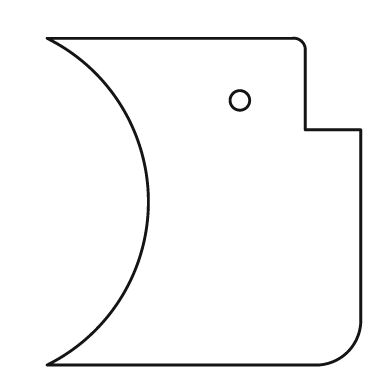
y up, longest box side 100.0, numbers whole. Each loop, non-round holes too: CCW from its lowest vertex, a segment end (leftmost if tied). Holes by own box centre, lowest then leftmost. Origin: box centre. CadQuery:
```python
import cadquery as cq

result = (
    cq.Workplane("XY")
    .moveTo(-48.0, -50.0)
    .lineTo(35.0, -50.0)
    .threePointArc((44.0, -46.0), (48.0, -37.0))
    .lineTo(48.0, 22.0)
    .lineTo(31.0, 22.0)
    .lineTo(31.0, 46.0)
    .threePointArc((30.0, 49.0), (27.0, 50.0))
    .lineTo(-48.0, 50.0)
    .threePointArc((-17.0, 0.0), (-48.0, -50.0))
    .close()
    .moveTo(11.0, 31.0)
    .circle(3.0)
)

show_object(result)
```